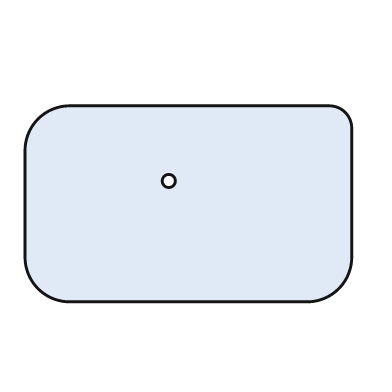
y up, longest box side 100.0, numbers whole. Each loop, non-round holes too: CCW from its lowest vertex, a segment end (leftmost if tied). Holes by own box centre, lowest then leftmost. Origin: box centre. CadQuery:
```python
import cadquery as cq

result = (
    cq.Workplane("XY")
    .moveTo(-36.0, -30.0)
    .lineTo(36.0, -30.0)
    .threePointArc((46.0, -26.0), (50.0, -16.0))
    .lineTo(50.0, 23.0)
    .threePointArc((48.0, 28.0), (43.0, 30.0))
    .lineTo(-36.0, 30.0)
    .threePointArc((-46.0, 26.0), (-50.0, 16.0))
    .lineTo(-50.0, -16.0)
    .threePointArc((-46.0, -26.0), (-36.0, -30.0))
    .close()
    .moveTo(-6.0, 7.0)
    .circle(2.0)
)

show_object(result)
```